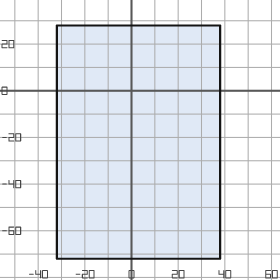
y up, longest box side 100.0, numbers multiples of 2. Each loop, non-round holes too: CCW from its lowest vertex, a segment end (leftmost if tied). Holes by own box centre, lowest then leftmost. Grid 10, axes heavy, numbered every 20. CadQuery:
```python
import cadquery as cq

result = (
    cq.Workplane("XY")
    .moveTo(-32.0, -72.0)
    .lineTo(38.0, -72.0)
    .lineTo(38.0, 28.0)
    .lineTo(-32.0, 28.0)
    .close()
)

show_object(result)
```